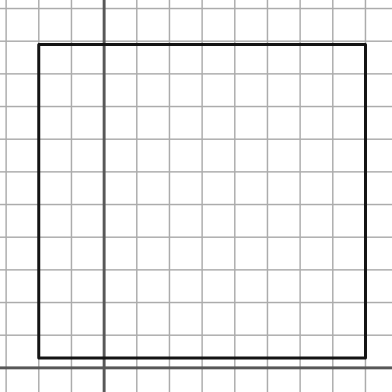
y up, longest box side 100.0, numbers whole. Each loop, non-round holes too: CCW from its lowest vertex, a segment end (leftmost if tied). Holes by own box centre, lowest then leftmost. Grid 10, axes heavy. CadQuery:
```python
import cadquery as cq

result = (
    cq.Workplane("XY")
    .moveTo(-20.0, 3.0)
    .lineTo(80.0, 3.0)
    .lineTo(80.0, 99.0)
    .lineTo(-20.0, 99.0)
    .close()
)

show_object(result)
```